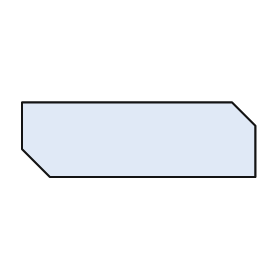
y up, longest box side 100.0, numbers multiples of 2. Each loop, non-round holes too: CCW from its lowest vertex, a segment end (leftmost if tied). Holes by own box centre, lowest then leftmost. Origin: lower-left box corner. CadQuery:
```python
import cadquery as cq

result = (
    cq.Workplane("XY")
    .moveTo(12.0, 0.0)
    .lineTo(100.0, 0.0)
    .lineTo(100.0, 22.0)
    .lineTo(90.0, 32.0)
    .lineTo(0.0, 32.0)
    .lineTo(0.0, 12.0)
    .close()
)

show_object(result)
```